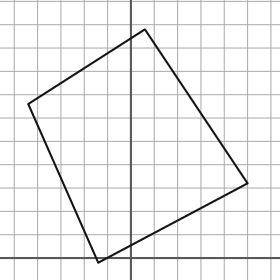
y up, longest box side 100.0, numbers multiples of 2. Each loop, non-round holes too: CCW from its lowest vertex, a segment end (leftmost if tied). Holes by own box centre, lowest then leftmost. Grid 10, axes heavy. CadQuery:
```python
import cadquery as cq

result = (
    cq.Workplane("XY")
    .moveTo(-14.0, -2.0)
    .lineTo(50.0, 32.0)
    .lineTo(6.0, 98.0)
    .lineTo(-44.0, 66.0)
    .close()
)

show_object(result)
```